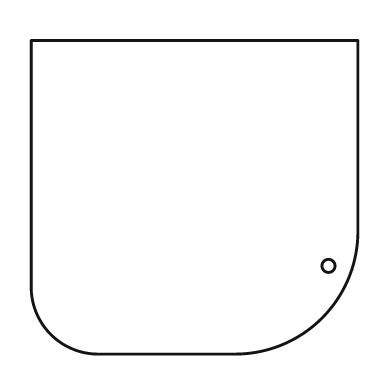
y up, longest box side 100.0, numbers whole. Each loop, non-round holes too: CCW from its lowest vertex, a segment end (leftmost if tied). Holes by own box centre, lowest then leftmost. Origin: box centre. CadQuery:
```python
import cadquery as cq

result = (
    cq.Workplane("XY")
    .moveTo(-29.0, -48.0)
    .lineTo(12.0, -48.0)
    .threePointArc((39.0, -37.0), (50.0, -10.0))
    .lineTo(50.0, 48.0)
    .lineTo(-50.0, 48.0)
    .lineTo(-50.0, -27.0)
    .threePointArc((-44.0, -42.0), (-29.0, -48.0))
    .close()
    .moveTo(41.0, -21.0)
    .circle(2.0)
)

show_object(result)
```